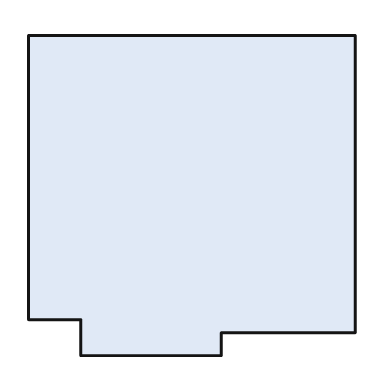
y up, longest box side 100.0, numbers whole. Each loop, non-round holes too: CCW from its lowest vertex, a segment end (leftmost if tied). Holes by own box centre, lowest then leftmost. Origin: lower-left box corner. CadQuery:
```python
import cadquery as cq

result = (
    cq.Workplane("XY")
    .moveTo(16.0, 0.0)
    .lineTo(59.0, 0.0)
    .lineTo(59.0, 7.0)
    .lineTo(100.0, 7.0)
    .lineTo(100.0, 98.0)
    .lineTo(0.0, 98.0)
    .lineTo(0.0, 11.0)
    .lineTo(16.0, 11.0)
    .close()
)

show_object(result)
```